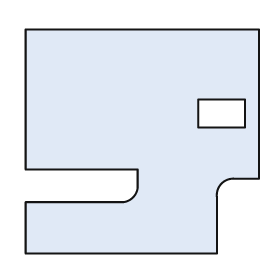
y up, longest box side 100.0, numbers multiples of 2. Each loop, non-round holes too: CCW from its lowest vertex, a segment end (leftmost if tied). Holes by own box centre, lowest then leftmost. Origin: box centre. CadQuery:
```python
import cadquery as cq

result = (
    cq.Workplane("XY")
    .moveTo(-50.0, -48.0)
    .lineTo(32.0, -48.0)
    .lineTo(32.0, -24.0)
    .threePointArc((34.0, -18.0), (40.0, -16.0))
    .lineTo(50.0, -16.0)
    .lineTo(50.0, 48.0)
    .lineTo(-50.0, 48.0)
    .lineTo(-50.0, -12.0)
    .lineTo(-2.0, -12.0)
    .lineTo(-2.0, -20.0)
    .threePointArc((-4.0, -24.0), (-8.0, -26.0))
    .lineTo(-50.0, -26.0)
    .close()
    .moveTo(24.0, 6.0)
    .lineTo(44.0, 6.0)
    .lineTo(44.0, 18.0)
    .lineTo(24.0, 18.0)
    .close()
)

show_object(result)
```